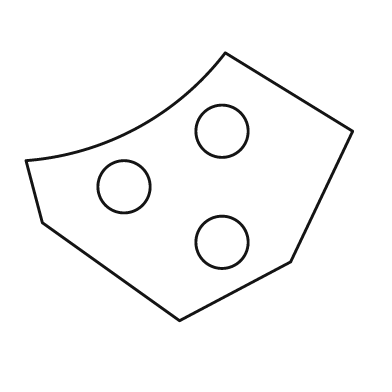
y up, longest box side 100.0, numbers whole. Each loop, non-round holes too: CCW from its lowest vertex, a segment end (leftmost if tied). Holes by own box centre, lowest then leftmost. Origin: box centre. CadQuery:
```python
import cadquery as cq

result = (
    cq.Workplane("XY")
    .moveTo(-3.0, -41.0)
    .lineTo(31.0, -23.0)
    .lineTo(50.0, 17.0)
    .lineTo(11.0, 41.0)
    .threePointArc((-16.0, 18.0), (-50.0, 8.0))
    .lineTo(-45.0, -11.0)
    .close()
    .moveTo(10.0, -17.0)
    .circle(8.0)
    .moveTo(-20.0, 0.0)
    .circle(8.0)
    .moveTo(10.0, 17.0)
    .circle(8.0)
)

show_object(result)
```